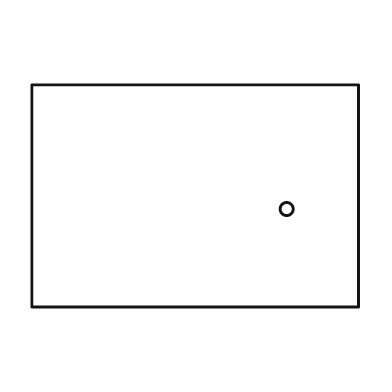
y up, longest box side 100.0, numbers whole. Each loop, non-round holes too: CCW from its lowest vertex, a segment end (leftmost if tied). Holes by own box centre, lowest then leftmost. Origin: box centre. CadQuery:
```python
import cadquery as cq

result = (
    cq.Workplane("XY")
    .moveTo(-50.0, -34.0)
    .lineTo(50.0, -34.0)
    .lineTo(50.0, 34.0)
    .lineTo(-50.0, 34.0)
    .close()
    .moveTo(28.0, -4.0)
    .circle(2.0)
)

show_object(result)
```